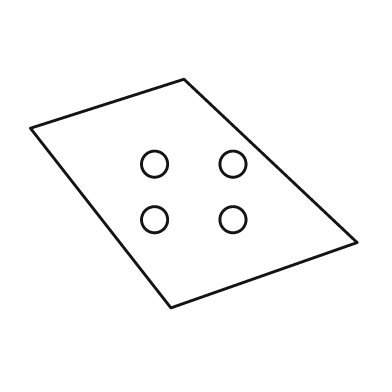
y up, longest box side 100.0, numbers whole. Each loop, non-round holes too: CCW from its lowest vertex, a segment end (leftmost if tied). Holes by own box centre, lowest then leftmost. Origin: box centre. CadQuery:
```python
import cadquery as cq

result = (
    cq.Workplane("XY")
    .moveTo(-7.0, -35.0)
    .lineTo(50.0, -15.0)
    .lineTo(-3.0, 35.0)
    .lineTo(-50.0, 20.0)
    .close()
    .moveTo(-12.0, -8.0)
    .circle(4.0)
    .moveTo(12.0, -8.0)
    .circle(4.0)
    .moveTo(-12.0, 9.0)
    .circle(4.0)
    .moveTo(12.0, 9.0)
    .circle(4.0)
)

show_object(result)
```